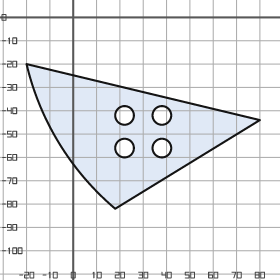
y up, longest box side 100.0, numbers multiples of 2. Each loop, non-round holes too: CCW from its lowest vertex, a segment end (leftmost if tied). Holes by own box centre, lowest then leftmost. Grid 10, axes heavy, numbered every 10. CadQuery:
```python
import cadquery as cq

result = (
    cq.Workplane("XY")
    .moveTo(18.0, -82.0)
    .lineTo(80.0, -44.0)
    .lineTo(-20.0, -20.0)
    .threePointArc((-6.0, -54.0), (18.0, -82.0))
    .close()
    .moveTo(22.0, -56.0)
    .circle(4.0)
    .moveTo(38.0, -56.0)
    .circle(4.0)
    .moveTo(22.0, -42.0)
    .circle(4.0)
    .moveTo(38.0, -42.0)
    .circle(4.0)
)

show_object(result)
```